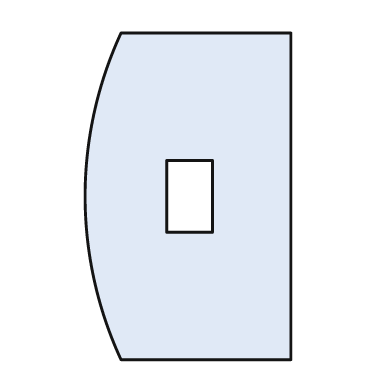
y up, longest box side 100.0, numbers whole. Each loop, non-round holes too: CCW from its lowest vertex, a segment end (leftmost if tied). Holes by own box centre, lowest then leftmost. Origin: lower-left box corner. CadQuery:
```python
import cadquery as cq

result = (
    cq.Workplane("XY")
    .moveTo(11.0, 0.0)
    .lineTo(63.0, 0.0)
    .lineTo(63.0, 100.0)
    .lineTo(11.0, 100.0)
    .threePointArc((0.0, 50.0), (11.0, 0.0))
    .close()
    .moveTo(25.0, 39.0)
    .lineTo(39.0, 39.0)
    .lineTo(39.0, 61.0)
    .lineTo(25.0, 61.0)
    .close()
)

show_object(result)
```